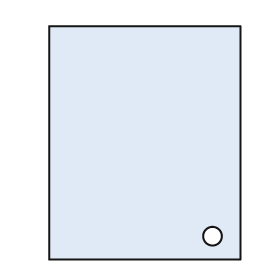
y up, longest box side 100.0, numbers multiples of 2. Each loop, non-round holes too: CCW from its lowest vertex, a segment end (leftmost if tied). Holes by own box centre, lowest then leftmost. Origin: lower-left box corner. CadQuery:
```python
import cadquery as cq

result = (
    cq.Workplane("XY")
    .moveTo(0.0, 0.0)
    .lineTo(82.0, 0.0)
    .lineTo(82.0, 100.0)
    .lineTo(0.0, 100.0)
    .close()
    .moveTo(70.0, 10.0)
    .circle(4.0)
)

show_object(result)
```